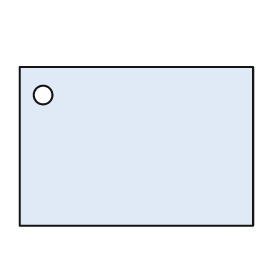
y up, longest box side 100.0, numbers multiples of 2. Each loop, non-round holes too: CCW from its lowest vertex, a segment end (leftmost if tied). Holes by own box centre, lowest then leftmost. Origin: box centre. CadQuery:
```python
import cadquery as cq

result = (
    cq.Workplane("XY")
    .moveTo(-50.0, -34.0)
    .lineTo(50.0, -34.0)
    .lineTo(50.0, 34.0)
    .lineTo(-50.0, 34.0)
    .close()
    .moveTo(-40.0, 22.0)
    .circle(4.0)
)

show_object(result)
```